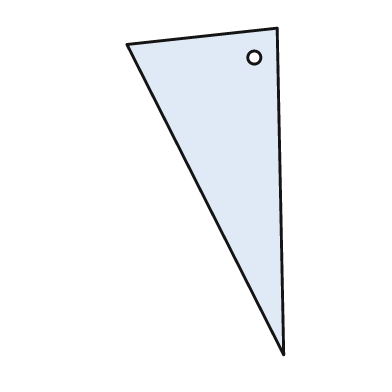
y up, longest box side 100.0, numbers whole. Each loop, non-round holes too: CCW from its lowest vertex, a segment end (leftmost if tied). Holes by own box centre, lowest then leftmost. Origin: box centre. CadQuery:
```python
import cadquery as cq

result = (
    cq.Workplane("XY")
    .moveTo(24.0, -50.0)
    .lineTo(22.0, 50.0)
    .lineTo(-24.0, 45.0)
    .close()
    .moveTo(15.0, 41.0)
    .circle(2.0)
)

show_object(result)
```